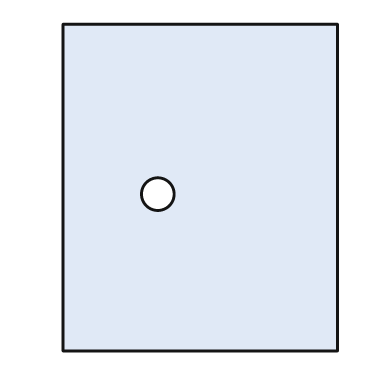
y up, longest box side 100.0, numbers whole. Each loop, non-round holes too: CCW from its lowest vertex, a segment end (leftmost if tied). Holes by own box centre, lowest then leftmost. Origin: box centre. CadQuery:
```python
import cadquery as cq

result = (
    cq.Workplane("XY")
    .moveTo(-42.0, -50.0)
    .lineTo(42.0, -50.0)
    .lineTo(42.0, 50.0)
    .lineTo(-42.0, 50.0)
    .close()
    .moveTo(-13.0, -2.0)
    .circle(5.0)
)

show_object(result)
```